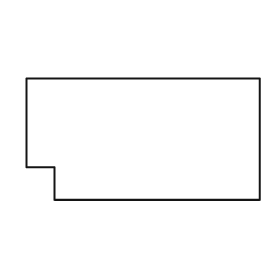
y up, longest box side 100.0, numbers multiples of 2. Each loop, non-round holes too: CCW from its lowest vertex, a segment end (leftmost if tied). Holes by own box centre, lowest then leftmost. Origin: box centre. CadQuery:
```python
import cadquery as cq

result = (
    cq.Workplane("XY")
    .moveTo(-38.0, -26.0)
    .lineTo(50.0, -26.0)
    .lineTo(50.0, 26.0)
    .lineTo(-50.0, 26.0)
    .lineTo(-50.0, -12.0)
    .lineTo(-38.0, -12.0)
    .close()
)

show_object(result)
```